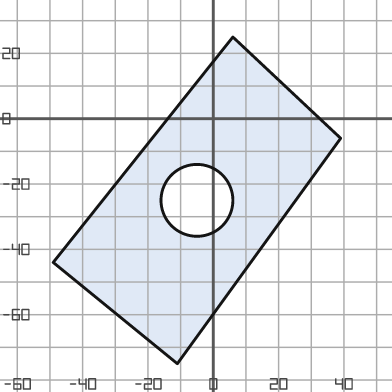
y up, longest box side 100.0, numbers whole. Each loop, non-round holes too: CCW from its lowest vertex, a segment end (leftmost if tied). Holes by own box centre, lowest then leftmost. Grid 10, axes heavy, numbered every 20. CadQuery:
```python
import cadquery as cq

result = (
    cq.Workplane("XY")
    .moveTo(-11.0, -75.0)
    .lineTo(39.0, -6.0)
    .lineTo(6.0, 25.0)
    .lineTo(-49.0, -44.0)
    .close()
    .moveTo(-5.0, -25.0)
    .circle(11.0)
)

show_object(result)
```